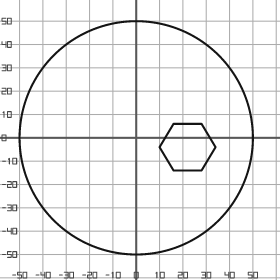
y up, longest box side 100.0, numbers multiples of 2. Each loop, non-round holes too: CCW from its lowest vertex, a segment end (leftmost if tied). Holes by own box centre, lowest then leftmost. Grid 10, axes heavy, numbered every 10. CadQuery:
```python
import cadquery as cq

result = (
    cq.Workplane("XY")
    .moveTo(0.0, 0.0)
    .circle(50.0)
    .moveTo(16.0, -14.0)
    .lineTo(28.0, -14.0)
    .lineTo(34.0, -4.0)
    .lineTo(28.0, 6.0)
    .lineTo(16.0, 6.0)
    .lineTo(10.0, -4.0)
    .close()
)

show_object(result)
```